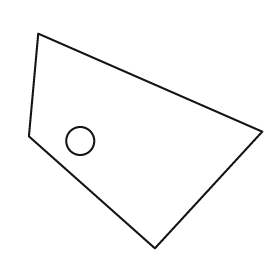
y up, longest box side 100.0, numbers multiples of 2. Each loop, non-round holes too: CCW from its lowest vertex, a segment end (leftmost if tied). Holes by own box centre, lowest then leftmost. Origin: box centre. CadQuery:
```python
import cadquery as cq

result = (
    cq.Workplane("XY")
    .moveTo(4.0, -46.0)
    .lineTo(50.0, 4.0)
    .lineTo(-46.0, 46.0)
    .lineTo(-50.0, 2.0)
    .close()
    .moveTo(-28.0, 0.0)
    .circle(6.0)
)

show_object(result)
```